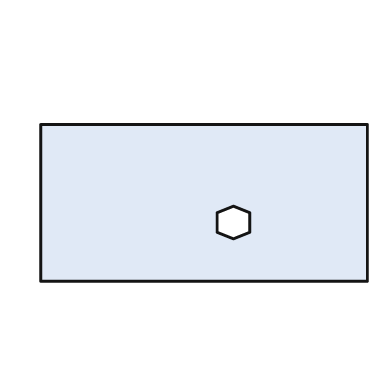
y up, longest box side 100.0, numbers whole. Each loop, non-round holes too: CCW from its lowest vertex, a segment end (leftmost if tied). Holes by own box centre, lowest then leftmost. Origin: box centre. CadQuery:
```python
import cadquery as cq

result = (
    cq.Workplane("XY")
    .moveTo(-50.0, -24.0)
    .lineTo(50.0, -24.0)
    .lineTo(50.0, 24.0)
    .lineTo(-50.0, 24.0)
    .close()
    .moveTo(9.0, -11.0)
    .lineTo(14.0, -9.0)
    .lineTo(14.0, -3.0)
    .lineTo(9.0, -1.0)
    .lineTo(4.0, -3.0)
    .lineTo(4.0, -9.0)
    .close()
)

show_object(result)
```